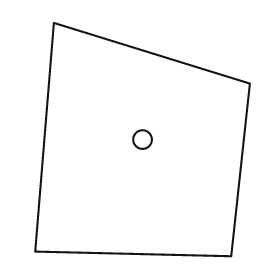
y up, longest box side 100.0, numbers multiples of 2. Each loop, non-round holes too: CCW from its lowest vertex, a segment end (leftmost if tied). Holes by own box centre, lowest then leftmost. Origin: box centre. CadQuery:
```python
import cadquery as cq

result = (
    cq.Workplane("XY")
    .moveTo(38.0, -50.0)
    .lineTo(46.0, 24.0)
    .lineTo(-38.0, 50.0)
    .lineTo(-46.0, -48.0)
    .close()
    .moveTo(0.0, 0.0)
    .circle(4.0)
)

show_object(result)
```